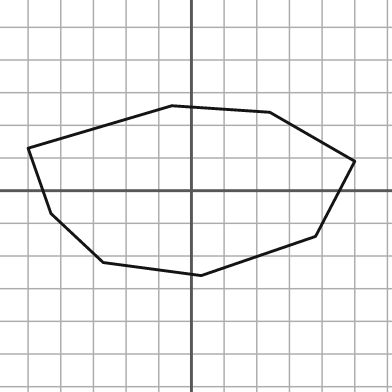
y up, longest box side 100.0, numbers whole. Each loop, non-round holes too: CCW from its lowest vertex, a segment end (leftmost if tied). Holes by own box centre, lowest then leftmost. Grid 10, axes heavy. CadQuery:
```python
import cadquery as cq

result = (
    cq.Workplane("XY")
    .moveTo(3.0, -26.0)
    .lineTo(38.0, -14.0)
    .lineTo(50.0, 9.0)
    .lineTo(24.0, 24.0)
    .lineTo(-6.0, 26.0)
    .lineTo(-50.0, 13.0)
    .lineTo(-43.0, -7.0)
    .lineTo(-27.0, -22.0)
    .close()
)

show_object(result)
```